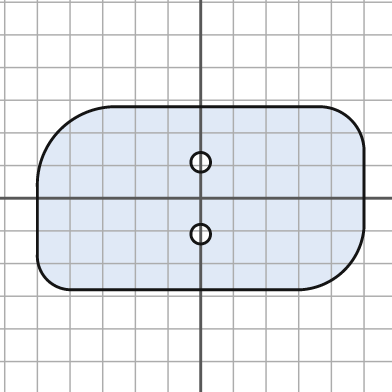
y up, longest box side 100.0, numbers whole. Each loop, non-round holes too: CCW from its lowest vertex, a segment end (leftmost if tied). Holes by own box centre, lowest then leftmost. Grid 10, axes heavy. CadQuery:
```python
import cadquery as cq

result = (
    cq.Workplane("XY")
    .moveTo(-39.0, -28.0)
    .lineTo(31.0, -28.0)
    .threePointArc((44.0, -22.0), (50.0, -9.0))
    .lineTo(50.0, 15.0)
    .threePointArc((46.0, 24.0), (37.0, 28.0))
    .lineTo(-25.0, 28.0)
    .threePointArc((-43.0, 21.0), (-50.0, 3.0))
    .lineTo(-50.0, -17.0)
    .threePointArc((-47.0, -25.0), (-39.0, -28.0))
    .close()
    .moveTo(0.0, -11.0)
    .circle(3.0)
    .moveTo(0.0, 11.0)
    .circle(3.0)
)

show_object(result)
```